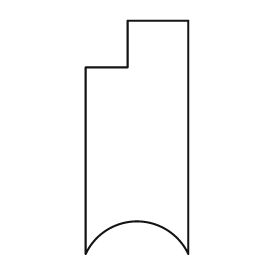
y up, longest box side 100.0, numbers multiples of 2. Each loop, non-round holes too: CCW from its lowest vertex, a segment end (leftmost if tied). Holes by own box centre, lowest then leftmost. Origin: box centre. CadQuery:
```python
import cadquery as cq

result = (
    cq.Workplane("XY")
    .moveTo(-22.0, -50.0)
    .threePointArc((0.0, -36.0), (22.0, -50.0))
    .lineTo(22.0, 50.0)
    .lineTo(-4.0, 50.0)
    .lineTo(-4.0, 30.0)
    .lineTo(-22.0, 30.0)
    .close()
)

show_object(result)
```